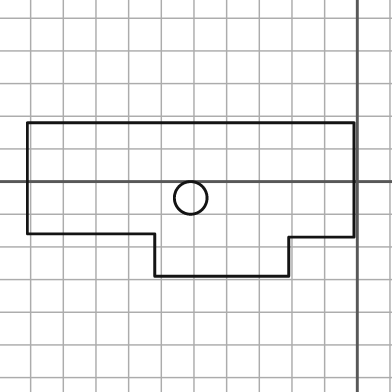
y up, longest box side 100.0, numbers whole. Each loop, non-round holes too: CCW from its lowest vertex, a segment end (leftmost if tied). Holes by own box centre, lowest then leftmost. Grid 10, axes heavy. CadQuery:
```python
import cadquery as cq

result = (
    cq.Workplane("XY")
    .moveTo(-62.0, -29.0)
    .lineTo(-21.0, -29.0)
    .lineTo(-21.0, -17.0)
    .lineTo(-1.0, -17.0)
    .lineTo(-1.0, 18.0)
    .lineTo(-101.0, 18.0)
    .lineTo(-101.0, -16.0)
    .lineTo(-62.0, -16.0)
    .close()
    .moveTo(-51.0, -5.0)
    .circle(5.0)
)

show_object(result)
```